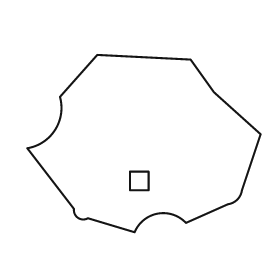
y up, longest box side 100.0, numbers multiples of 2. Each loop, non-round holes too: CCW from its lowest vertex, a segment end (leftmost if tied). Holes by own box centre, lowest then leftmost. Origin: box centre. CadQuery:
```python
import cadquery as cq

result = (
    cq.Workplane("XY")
    .moveTo(-4.0, -38.0)
    .threePointArc((6.0, -30.0), (18.0, -34.0))
    .lineTo(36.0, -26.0)
    .threePointArc((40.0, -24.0), (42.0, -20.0))
    .lineTo(50.0, 4.0)
    .lineTo(30.0, 22.0)
    .lineTo(20.0, 36.0)
    .lineTo(-20.0, 38.0)
    .lineTo(-36.0, 20.0)
    .threePointArc((-38.0, 6.0), (-50.0, -2.0))
    .lineTo(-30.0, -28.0)
    .threePointArc((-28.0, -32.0), (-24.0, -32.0))
    .close()
    .moveTo(-6.0, -20.0)
    .lineTo(2.0, -20.0)
    .lineTo(2.0, -12.0)
    .lineTo(-6.0, -12.0)
    .close()
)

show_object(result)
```